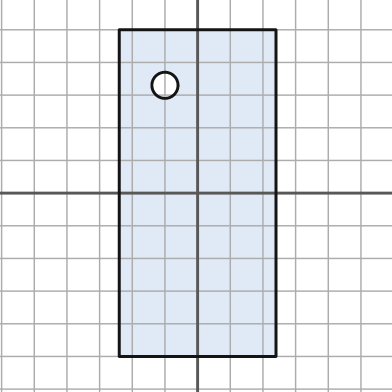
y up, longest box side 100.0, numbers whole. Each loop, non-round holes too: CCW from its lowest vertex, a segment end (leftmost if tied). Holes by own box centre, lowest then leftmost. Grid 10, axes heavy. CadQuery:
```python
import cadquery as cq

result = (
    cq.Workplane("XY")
    .moveTo(-24.0, -50.0)
    .lineTo(24.0, -50.0)
    .lineTo(24.0, 50.0)
    .lineTo(-24.0, 50.0)
    .close()
    .moveTo(-10.0, 33.0)
    .circle(4.0)
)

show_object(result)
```